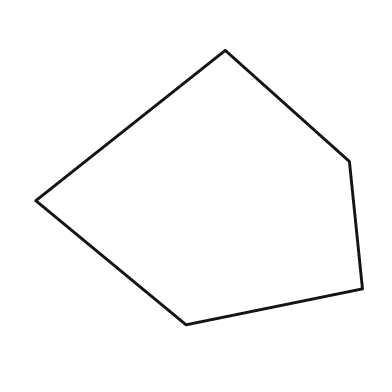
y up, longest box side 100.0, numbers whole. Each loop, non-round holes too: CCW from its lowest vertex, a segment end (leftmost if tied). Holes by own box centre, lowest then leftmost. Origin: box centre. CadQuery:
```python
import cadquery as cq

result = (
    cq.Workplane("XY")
    .moveTo(-4.0, -42.0)
    .lineTo(50.0, -31.0)
    .lineTo(46.0, 8.0)
    .lineTo(8.0, 42.0)
    .lineTo(-50.0, -4.0)
    .close()
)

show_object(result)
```